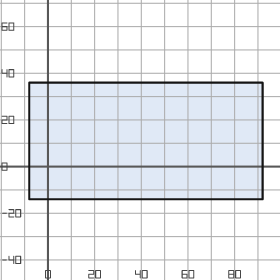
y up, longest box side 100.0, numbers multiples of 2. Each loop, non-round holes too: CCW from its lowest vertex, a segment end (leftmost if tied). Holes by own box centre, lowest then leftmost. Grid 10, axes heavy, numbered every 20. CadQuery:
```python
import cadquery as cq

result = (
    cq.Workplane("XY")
    .moveTo(-8.0, -14.0)
    .lineTo(92.0, -14.0)
    .lineTo(92.0, 36.0)
    .lineTo(-8.0, 36.0)
    .close()
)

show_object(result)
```